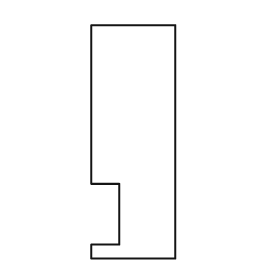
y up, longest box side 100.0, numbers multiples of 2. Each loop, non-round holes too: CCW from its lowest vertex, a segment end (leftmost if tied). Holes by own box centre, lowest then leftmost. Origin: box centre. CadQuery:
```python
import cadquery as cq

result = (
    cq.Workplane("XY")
    .moveTo(-18.0, -50.0)
    .lineTo(18.0, -50.0)
    .lineTo(18.0, 50.0)
    .lineTo(-18.0, 50.0)
    .lineTo(-18.0, -18.0)
    .lineTo(-6.0, -18.0)
    .lineTo(-6.0, -44.0)
    .lineTo(-18.0, -44.0)
    .close()
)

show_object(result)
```